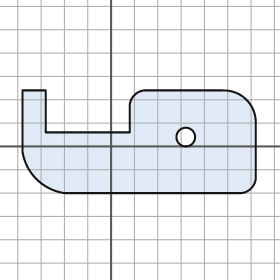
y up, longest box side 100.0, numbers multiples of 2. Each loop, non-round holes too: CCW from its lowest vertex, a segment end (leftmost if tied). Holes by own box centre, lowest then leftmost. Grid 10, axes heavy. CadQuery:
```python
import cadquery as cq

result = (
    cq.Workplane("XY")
    .moveTo(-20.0, -20.0)
    .lineTo(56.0, -20.0)
    .threePointArc((60.0, -18.0), (62.0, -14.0))
    .lineTo(62.0, 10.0)
    .threePointArc((58.0, 20.0), (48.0, 24.0))
    .lineTo(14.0, 24.0)
    .threePointArc((10.0, 22.0), (8.0, 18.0))
    .lineTo(8.0, 6.0)
    .lineTo(-28.0, 6.0)
    .lineTo(-28.0, 24.0)
    .lineTo(-38.0, 24.0)
    .lineTo(-38.0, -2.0)
    .threePointArc((-32.0, -14.0), (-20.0, -20.0))
    .close()
    .moveTo(32.0, 4.0)
    .circle(4.0)
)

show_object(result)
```